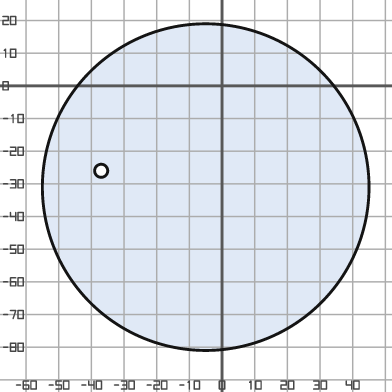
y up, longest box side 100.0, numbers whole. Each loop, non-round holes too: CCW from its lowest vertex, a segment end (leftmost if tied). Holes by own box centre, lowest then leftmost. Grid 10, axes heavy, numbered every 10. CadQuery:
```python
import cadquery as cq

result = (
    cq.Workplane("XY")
    .moveTo(-5.0, -31.0)
    .circle(50.0)
    .moveTo(-37.0, -26.0)
    .circle(2.0)
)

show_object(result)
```